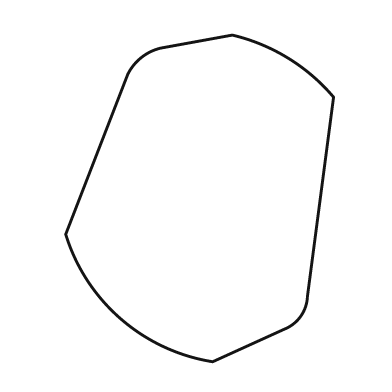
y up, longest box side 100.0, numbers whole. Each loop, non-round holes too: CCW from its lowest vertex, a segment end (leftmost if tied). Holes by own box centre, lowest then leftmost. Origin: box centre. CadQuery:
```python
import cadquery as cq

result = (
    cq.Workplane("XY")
    .moveTo(4.0, -50.0)
    .lineTo(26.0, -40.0)
    .threePointArc((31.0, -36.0), (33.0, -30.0))
    .lineTo(41.0, 31.0)
    .threePointArc((27.0, 43.0), (10.0, 50.0))
    .lineTo(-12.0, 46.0)
    .threePointArc((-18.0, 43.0), (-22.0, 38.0))
    .lineTo(-41.0, -11.0)
    .threePointArc((-24.0, -37.0), (4.0, -50.0))
    .close()
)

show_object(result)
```